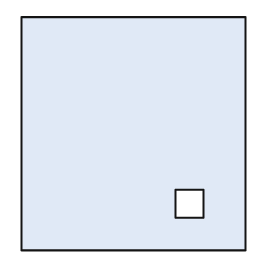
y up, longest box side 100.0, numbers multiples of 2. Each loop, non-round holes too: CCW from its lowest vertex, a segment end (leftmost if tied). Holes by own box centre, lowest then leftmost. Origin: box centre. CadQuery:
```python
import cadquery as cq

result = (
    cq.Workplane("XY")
    .moveTo(-48.0, -50.0)
    .lineTo(48.0, -50.0)
    .lineTo(48.0, 50.0)
    .lineTo(-48.0, 50.0)
    .close()
    .moveTo(18.0, -36.0)
    .lineTo(30.0, -36.0)
    .lineTo(30.0, -24.0)
    .lineTo(18.0, -24.0)
    .close()
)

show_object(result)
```